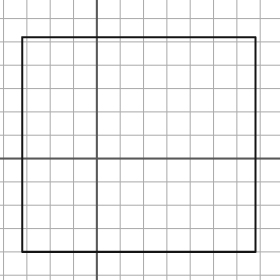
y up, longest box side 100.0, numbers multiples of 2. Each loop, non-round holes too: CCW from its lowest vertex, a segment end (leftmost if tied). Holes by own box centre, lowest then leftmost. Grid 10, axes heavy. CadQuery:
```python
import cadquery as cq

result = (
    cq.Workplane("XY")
    .moveTo(-32.0, -40.0)
    .lineTo(68.0, -40.0)
    .lineTo(68.0, 52.0)
    .lineTo(-32.0, 52.0)
    .close()
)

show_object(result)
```